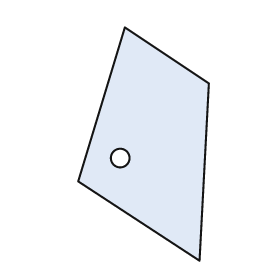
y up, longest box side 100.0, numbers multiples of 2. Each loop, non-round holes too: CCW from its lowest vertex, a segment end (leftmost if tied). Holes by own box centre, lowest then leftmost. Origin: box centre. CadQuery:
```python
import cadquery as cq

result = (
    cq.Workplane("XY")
    .moveTo(24.0, -50.0)
    .lineTo(28.0, 26.0)
    .lineTo(-8.0, 50.0)
    .lineTo(-28.0, -16.0)
    .close()
    .moveTo(-10.0, -6.0)
    .circle(4.0)
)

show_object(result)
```